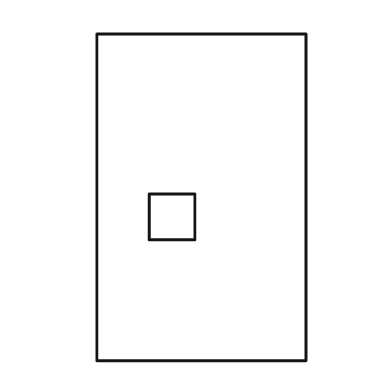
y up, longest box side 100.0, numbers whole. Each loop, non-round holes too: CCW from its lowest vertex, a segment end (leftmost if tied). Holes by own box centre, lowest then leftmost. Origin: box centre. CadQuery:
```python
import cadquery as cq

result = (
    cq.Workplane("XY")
    .moveTo(-32.0, -50.0)
    .lineTo(32.0, -50.0)
    .lineTo(32.0, 50.0)
    .lineTo(-32.0, 50.0)
    .close()
    .moveTo(-16.0, -13.0)
    .lineTo(-2.0, -13.0)
    .lineTo(-2.0, 1.0)
    .lineTo(-16.0, 1.0)
    .close()
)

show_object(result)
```